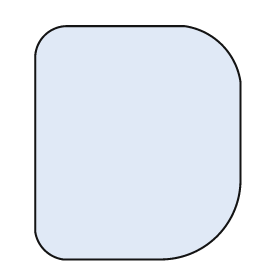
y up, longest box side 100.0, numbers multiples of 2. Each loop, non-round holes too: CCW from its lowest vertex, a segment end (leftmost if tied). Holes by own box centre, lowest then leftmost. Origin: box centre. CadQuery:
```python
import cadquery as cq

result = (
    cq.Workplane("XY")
    .moveTo(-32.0, -50.0)
    .lineTo(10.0, -50.0)
    .threePointArc((34.0, -40.0), (44.0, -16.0))
    .lineTo(44.0, 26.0)
    .threePointArc((36.0, 42.0), (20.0, 50.0))
    .lineTo(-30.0, 50.0)
    .threePointArc((-40.0, 46.0), (-44.0, 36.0))
    .lineTo(-44.0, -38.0)
    .threePointArc((-40.0, -46.0), (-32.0, -50.0))
    .close()
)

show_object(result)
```